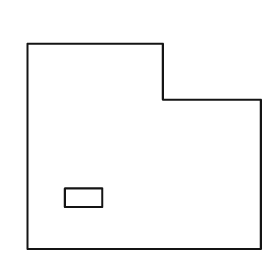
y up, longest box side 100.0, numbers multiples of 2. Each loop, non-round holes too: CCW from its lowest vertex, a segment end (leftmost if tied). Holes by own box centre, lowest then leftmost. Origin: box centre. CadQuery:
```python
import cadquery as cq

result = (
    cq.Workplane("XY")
    .moveTo(-50.0, -44.0)
    .lineTo(50.0, -44.0)
    .lineTo(50.0, 20.0)
    .lineTo(8.0, 20.0)
    .lineTo(8.0, 44.0)
    .lineTo(-50.0, 44.0)
    .close()
    .moveTo(-34.0, -26.0)
    .lineTo(-18.0, -26.0)
    .lineTo(-18.0, -18.0)
    .lineTo(-34.0, -18.0)
    .close()
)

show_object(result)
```